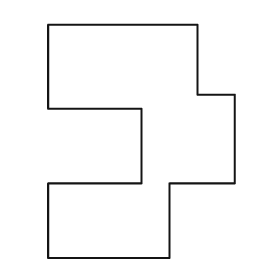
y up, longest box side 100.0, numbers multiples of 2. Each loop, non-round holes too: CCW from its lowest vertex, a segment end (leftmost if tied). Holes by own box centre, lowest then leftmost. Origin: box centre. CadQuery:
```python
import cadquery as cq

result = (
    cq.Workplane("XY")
    .moveTo(-40.0, -50.0)
    .lineTo(12.0, -50.0)
    .lineTo(12.0, -18.0)
    .lineTo(40.0, -18.0)
    .lineTo(40.0, 20.0)
    .lineTo(24.0, 20.0)
    .lineTo(24.0, 50.0)
    .lineTo(-40.0, 50.0)
    .lineTo(-40.0, 14.0)
    .lineTo(0.0, 14.0)
    .lineTo(0.0, -18.0)
    .lineTo(-40.0, -18.0)
    .close()
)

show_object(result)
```